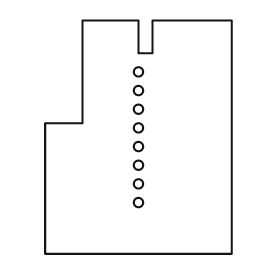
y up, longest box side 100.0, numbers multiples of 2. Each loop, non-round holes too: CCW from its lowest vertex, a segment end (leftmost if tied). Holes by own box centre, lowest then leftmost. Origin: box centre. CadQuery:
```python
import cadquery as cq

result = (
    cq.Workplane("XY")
    .moveTo(-40.0, -50.0)
    .lineTo(40.0, -50.0)
    .lineTo(40.0, 50.0)
    .lineTo(6.0, 50.0)
    .lineTo(6.0, 36.0)
    .lineTo(0.0, 36.0)
    .lineTo(0.0, 50.0)
    .lineTo(-24.0, 50.0)
    .lineTo(-24.0, 6.0)
    .lineTo(-40.0, 6.0)
    .close()
    .moveTo(0.0, -28.0)
    .circle(2.0)
    .moveTo(0.0, -20.0)
    .circle(2.0)
    .moveTo(0.0, -12.0)
    .circle(2.0)
    .moveTo(0.0, -4.0)
    .circle(2.0)
    .moveTo(0.0, 4.0)
    .circle(2.0)
    .moveTo(0.0, 12.0)
    .circle(2.0)
    .moveTo(0.0, 20.0)
    .circle(2.0)
    .moveTo(0.0, 28.0)
    .circle(2.0)
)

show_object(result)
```